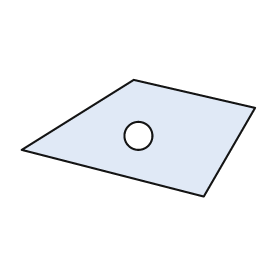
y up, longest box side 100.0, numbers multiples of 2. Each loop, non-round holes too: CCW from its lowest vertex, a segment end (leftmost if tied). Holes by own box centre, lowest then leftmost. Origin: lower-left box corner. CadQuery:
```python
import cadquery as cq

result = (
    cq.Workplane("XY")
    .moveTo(78.0, 0.0)
    .lineTo(100.0, 38.0)
    .lineTo(48.0, 50.0)
    .lineTo(0.0, 20.0)
    .close()
    .moveTo(50.0, 26.0)
    .circle(6.0)
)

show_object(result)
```